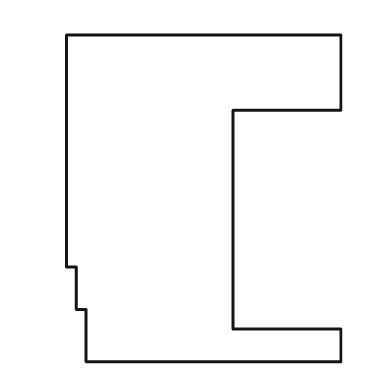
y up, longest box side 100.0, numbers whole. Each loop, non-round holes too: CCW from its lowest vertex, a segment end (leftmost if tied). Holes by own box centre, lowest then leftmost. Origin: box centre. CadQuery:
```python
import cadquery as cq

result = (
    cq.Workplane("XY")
    .moveTo(-36.0, -50.0)
    .lineTo(42.0, -50.0)
    .lineTo(42.0, -40.0)
    .lineTo(9.0, -40.0)
    .lineTo(9.0, 27.0)
    .lineTo(42.0, 27.0)
    .lineTo(42.0, 50.0)
    .lineTo(-42.0, 50.0)
    .lineTo(-42.0, -21.0)
    .lineTo(-39.0, -21.0)
    .lineTo(-39.0, -34.0)
    .lineTo(-36.0, -34.0)
    .close()
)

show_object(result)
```